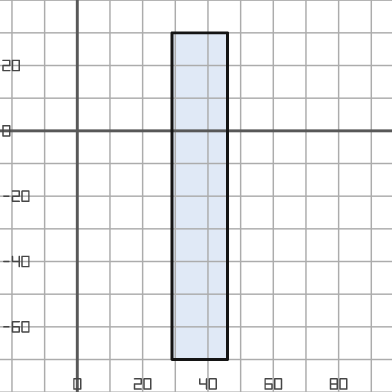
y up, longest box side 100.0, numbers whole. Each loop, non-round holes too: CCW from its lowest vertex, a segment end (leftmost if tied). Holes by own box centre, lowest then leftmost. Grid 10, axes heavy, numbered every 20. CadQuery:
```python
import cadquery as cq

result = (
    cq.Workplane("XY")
    .moveTo(29.0, -70.0)
    .lineTo(46.0, -70.0)
    .lineTo(46.0, 30.0)
    .lineTo(29.0, 30.0)
    .close()
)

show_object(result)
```